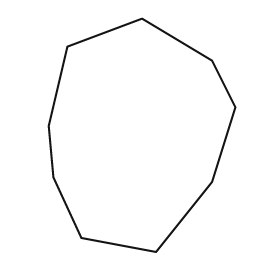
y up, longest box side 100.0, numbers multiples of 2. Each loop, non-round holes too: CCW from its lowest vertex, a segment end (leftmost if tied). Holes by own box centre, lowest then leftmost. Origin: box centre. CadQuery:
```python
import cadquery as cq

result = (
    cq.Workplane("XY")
    .moveTo(6.0, -50.0)
    .lineTo(30.0, -20.0)
    .lineTo(40.0, 12.0)
    .lineTo(30.0, 32.0)
    .lineTo(0.0, 50.0)
    .lineTo(-32.0, 38.0)
    .lineTo(-40.0, 4.0)
    .lineTo(-38.0, -18.0)
    .lineTo(-26.0, -44.0)
    .close()
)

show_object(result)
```